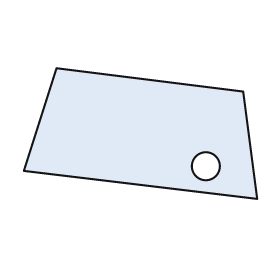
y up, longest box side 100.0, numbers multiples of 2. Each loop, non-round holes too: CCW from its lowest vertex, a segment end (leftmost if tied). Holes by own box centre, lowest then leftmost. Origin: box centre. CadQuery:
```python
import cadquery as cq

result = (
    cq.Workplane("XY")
    .moveTo(50.0, -28.0)
    .lineTo(44.0, 18.0)
    .lineTo(-36.0, 28.0)
    .lineTo(-50.0, -16.0)
    .close()
    .moveTo(28.0, -14.0)
    .circle(6.0)
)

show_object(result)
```